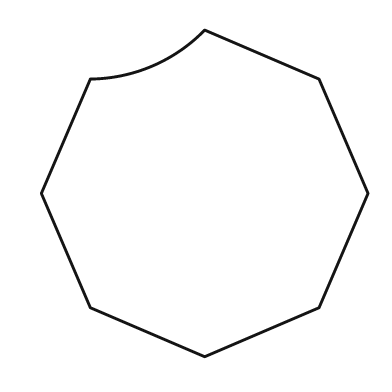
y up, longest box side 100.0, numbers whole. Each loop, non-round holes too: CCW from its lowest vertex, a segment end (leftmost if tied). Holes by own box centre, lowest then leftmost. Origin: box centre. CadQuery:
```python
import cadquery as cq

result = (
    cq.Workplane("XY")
    .moveTo(0.0, -50.0)
    .lineTo(35.0, -35.0)
    .lineTo(50.0, 0.0)
    .lineTo(35.0, 35.0)
    .lineTo(0.0, 50.0)
    .threePointArc((-16.0, 39.0), (-35.0, 35.0))
    .lineTo(-50.0, 0.0)
    .lineTo(-35.0, -35.0)
    .close()
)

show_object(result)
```